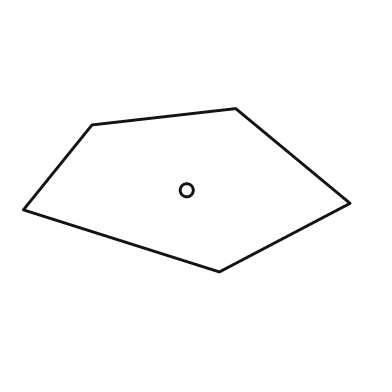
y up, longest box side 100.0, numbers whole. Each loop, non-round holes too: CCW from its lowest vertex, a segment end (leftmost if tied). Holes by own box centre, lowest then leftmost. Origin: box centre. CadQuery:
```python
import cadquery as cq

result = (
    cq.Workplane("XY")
    .moveTo(10.0, -25.0)
    .lineTo(50.0, -4.0)
    .lineTo(15.0, 25.0)
    .lineTo(-29.0, 20.0)
    .lineTo(-50.0, -6.0)
    .close()
    .moveTo(0.0, 0.0)
    .circle(2.0)
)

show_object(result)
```